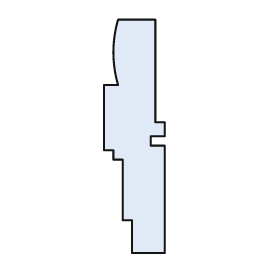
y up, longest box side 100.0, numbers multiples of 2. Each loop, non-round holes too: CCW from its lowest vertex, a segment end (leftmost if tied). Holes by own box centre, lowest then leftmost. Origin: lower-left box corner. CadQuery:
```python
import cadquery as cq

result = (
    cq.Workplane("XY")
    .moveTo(12.0, 0.0)
    .lineTo(26.0, 0.0)
    .lineTo(26.0, 46.0)
    .lineTo(20.0, 46.0)
    .lineTo(20.0, 50.0)
    .lineTo(26.0, 50.0)
    .lineTo(26.0, 56.0)
    .lineTo(22.0, 56.0)
    .lineTo(22.0, 100.0)
    .lineTo(6.0, 100.0)
    .threePointArc((4.0, 86.0), (6.0, 72.0))
    .lineTo(0.0, 72.0)
    .lineTo(0.0, 44.0)
    .lineTo(4.0, 44.0)
    .lineTo(4.0, 40.0)
    .lineTo(8.0, 40.0)
    .lineTo(8.0, 14.0)
    .lineTo(12.0, 14.0)
    .close()
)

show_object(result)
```